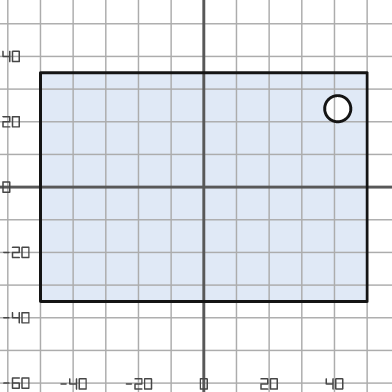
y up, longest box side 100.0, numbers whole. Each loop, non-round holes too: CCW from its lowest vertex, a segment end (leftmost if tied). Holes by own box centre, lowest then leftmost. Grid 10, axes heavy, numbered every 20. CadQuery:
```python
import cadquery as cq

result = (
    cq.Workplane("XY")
    .moveTo(-50.0, -35.0)
    .lineTo(50.0, -35.0)
    .lineTo(50.0, 35.0)
    .lineTo(-50.0, 35.0)
    .close()
    .moveTo(41.0, 24.0)
    .circle(4.0)
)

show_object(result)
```